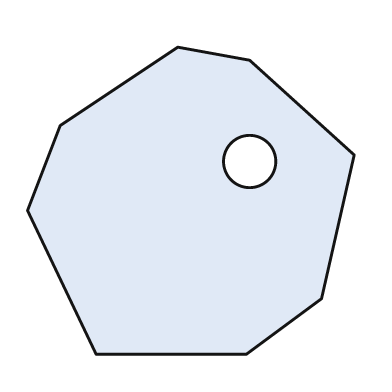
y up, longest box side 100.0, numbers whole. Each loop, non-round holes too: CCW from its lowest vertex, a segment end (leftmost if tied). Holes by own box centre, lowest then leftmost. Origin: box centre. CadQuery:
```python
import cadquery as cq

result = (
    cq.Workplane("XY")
    .moveTo(-29.0, -47.0)
    .lineTo(17.0, -47.0)
    .lineTo(40.0, -30.0)
    .lineTo(50.0, 14.0)
    .lineTo(18.0, 43.0)
    .lineTo(-4.0, 47.0)
    .lineTo(-40.0, 23.0)
    .lineTo(-50.0, -3.0)
    .close()
    .moveTo(18.0, 12.0)
    .circle(8.0)
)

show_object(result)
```